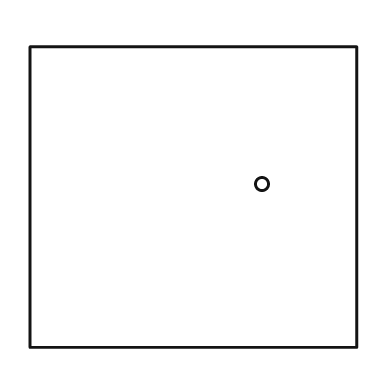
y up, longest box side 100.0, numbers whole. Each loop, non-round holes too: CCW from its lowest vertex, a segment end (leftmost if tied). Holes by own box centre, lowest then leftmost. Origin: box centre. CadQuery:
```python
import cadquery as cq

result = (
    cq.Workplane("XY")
    .moveTo(-50.0, -46.0)
    .lineTo(50.0, -46.0)
    .lineTo(50.0, 46.0)
    .lineTo(-50.0, 46.0)
    .close()
    .moveTo(21.0, 4.0)
    .circle(2.0)
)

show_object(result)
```